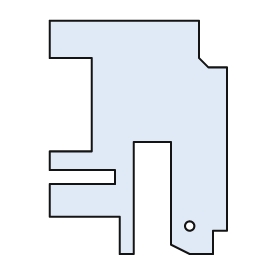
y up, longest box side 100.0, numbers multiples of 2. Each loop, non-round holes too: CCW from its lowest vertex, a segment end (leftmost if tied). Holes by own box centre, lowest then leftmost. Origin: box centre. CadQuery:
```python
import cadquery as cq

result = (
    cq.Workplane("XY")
    .moveTo(-8.0, -50.0)
    .lineTo(-2.0, -50.0)
    .lineTo(-2.0, -2.0)
    .lineTo(14.0, -2.0)
    .lineTo(14.0, -46.0)
    .lineTo(22.0, -50.0)
    .lineTo(32.0, -50.0)
    .lineTo(32.0, -40.0)
    .lineTo(38.0, -40.0)
    .lineTo(38.0, 30.0)
    .lineTo(30.0, 30.0)
    .lineTo(26.0, 34.0)
    .lineTo(26.0, 50.0)
    .lineTo(-38.0, 50.0)
    .lineTo(-38.0, 34.0)
    .lineTo(-20.0, 34.0)
    .lineTo(-20.0, -6.0)
    .lineTo(-38.0, -6.0)
    .lineTo(-38.0, -14.0)
    .lineTo(-10.0, -14.0)
    .lineTo(-10.0, -20.0)
    .lineTo(-38.0, -20.0)
    .lineTo(-38.0, -34.0)
    .lineTo(-8.0, -34.0)
    .close()
    .moveTo(22.0, -38.0)
    .circle(2.0)
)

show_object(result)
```